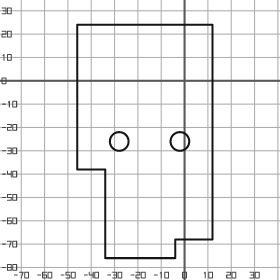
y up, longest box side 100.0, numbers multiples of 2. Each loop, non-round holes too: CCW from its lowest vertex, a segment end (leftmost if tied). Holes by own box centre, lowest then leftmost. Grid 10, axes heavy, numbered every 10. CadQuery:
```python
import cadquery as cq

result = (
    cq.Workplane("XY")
    .moveTo(-34.0, -76.0)
    .lineTo(-4.0, -76.0)
    .lineTo(-4.0, -68.0)
    .lineTo(12.0, -68.0)
    .lineTo(12.0, 24.0)
    .lineTo(-46.0, 24.0)
    .lineTo(-46.0, -38.0)
    .lineTo(-34.0, -38.0)
    .close()
    .moveTo(-28.0, -26.0)
    .circle(4.0)
    .moveTo(-2.0, -26.0)
    .circle(4.0)
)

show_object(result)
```